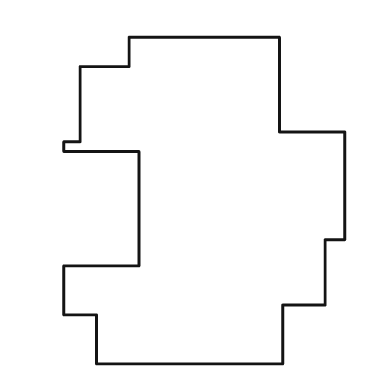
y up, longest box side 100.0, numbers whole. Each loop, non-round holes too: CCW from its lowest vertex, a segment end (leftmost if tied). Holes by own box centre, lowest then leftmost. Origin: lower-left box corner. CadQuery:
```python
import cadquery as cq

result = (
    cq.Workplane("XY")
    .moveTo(10.0, 0.0)
    .lineTo(67.0, 0.0)
    .lineTo(67.0, 18.0)
    .lineTo(80.0, 18.0)
    .lineTo(80.0, 38.0)
    .lineTo(86.0, 38.0)
    .lineTo(86.0, 71.0)
    .lineTo(66.0, 71.0)
    .lineTo(66.0, 100.0)
    .lineTo(20.0, 100.0)
    .lineTo(20.0, 91.0)
    .lineTo(5.0, 91.0)
    .lineTo(5.0, 68.0)
    .lineTo(0.0, 68.0)
    .lineTo(0.0, 65.0)
    .lineTo(23.0, 65.0)
    .lineTo(23.0, 30.0)
    .lineTo(0.0, 30.0)
    .lineTo(0.0, 15.0)
    .lineTo(10.0, 15.0)
    .close()
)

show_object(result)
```